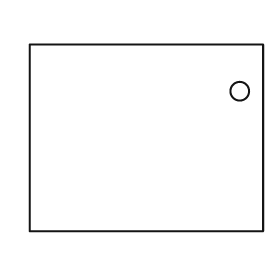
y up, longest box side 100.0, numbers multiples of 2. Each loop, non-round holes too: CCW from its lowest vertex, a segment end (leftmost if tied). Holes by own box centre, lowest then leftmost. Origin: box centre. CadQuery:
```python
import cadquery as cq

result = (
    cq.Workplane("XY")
    .moveTo(-50.0, -40.0)
    .lineTo(50.0, -40.0)
    .lineTo(50.0, 40.0)
    .lineTo(-50.0, 40.0)
    .close()
    .moveTo(40.0, 20.0)
    .circle(4.0)
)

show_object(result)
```